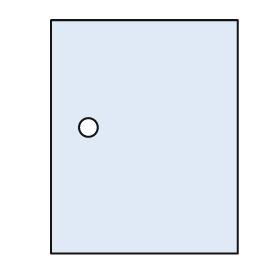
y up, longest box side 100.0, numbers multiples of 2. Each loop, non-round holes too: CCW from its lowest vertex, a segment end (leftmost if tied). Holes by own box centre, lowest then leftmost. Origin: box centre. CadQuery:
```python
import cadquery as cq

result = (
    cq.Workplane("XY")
    .moveTo(-40.0, -50.0)
    .lineTo(40.0, -50.0)
    .lineTo(40.0, 50.0)
    .lineTo(-40.0, 50.0)
    .close()
    .moveTo(-24.0, 4.0)
    .circle(4.0)
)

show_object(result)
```